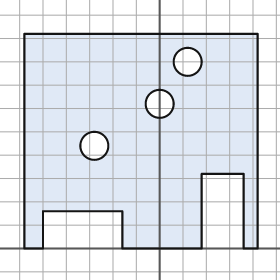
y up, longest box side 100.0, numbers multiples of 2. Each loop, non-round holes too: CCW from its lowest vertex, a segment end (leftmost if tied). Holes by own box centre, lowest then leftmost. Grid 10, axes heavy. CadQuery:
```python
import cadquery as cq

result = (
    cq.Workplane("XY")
    .moveTo(-58.0, 0.0)
    .lineTo(-50.0, 0.0)
    .lineTo(-50.0, 16.0)
    .lineTo(-16.0, 16.0)
    .lineTo(-16.0, 0.0)
    .lineTo(18.0, 0.0)
    .lineTo(18.0, 32.0)
    .lineTo(36.0, 32.0)
    .lineTo(36.0, 0.0)
    .lineTo(42.0, 0.0)
    .lineTo(42.0, 92.0)
    .lineTo(-58.0, 92.0)
    .close()
    .moveTo(-28.0, 44.0)
    .circle(6.0)
    .moveTo(0.0, 62.0)
    .circle(6.0)
    .moveTo(12.0, 80.0)
    .circle(6.0)
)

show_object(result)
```